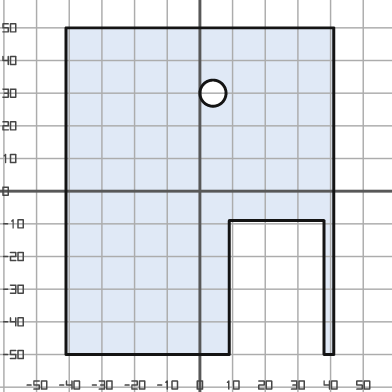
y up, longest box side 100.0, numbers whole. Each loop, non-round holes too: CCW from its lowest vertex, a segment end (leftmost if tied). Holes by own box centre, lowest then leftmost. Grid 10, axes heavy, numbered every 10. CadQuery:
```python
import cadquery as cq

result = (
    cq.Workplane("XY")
    .moveTo(-41.0, -50.0)
    .lineTo(9.0, -50.0)
    .lineTo(9.0, -9.0)
    .lineTo(38.0, -9.0)
    .lineTo(38.0, -50.0)
    .lineTo(41.0, -50.0)
    .lineTo(41.0, 50.0)
    .lineTo(-41.0, 50.0)
    .close()
    .moveTo(4.0, 30.0)
    .circle(4.0)
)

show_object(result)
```